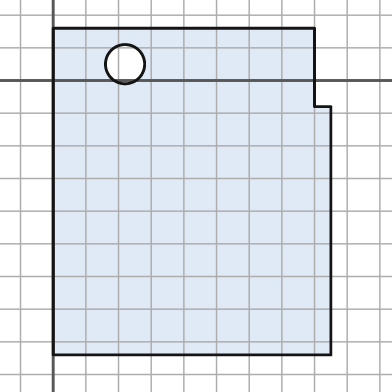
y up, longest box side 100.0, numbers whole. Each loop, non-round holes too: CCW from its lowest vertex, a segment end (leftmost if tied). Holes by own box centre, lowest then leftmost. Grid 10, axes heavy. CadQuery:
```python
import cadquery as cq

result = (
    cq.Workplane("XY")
    .moveTo(0.0, -84.0)
    .lineTo(85.0, -84.0)
    .lineTo(85.0, -8.0)
    .lineTo(80.0, -8.0)
    .lineTo(80.0, 16.0)
    .lineTo(0.0, 16.0)
    .close()
    .moveTo(22.0, 5.0)
    .circle(6.0)
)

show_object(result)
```